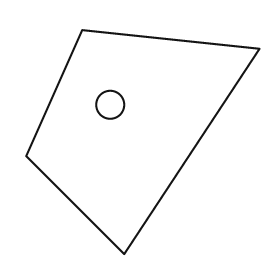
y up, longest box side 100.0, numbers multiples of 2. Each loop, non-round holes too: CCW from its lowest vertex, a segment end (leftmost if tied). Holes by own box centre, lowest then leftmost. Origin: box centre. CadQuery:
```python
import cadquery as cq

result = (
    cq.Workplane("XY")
    .moveTo(-8.0, -48.0)
    .lineTo(50.0, 40.0)
    .lineTo(-26.0, 48.0)
    .lineTo(-50.0, -6.0)
    .close()
    .moveTo(-14.0, 16.0)
    .circle(6.0)
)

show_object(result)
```